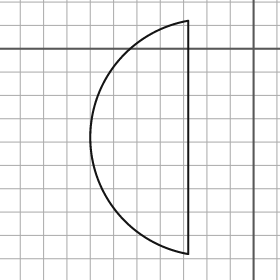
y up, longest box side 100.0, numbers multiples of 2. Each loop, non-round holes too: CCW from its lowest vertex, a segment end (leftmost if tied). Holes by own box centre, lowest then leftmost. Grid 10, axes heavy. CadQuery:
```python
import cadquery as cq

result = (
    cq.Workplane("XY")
    .moveTo(-28.0, -88.0)
    .lineTo(-28.0, 12.0)
    .threePointArc((-70.0, -38.0), (-28.0, -88.0))
    .close()
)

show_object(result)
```